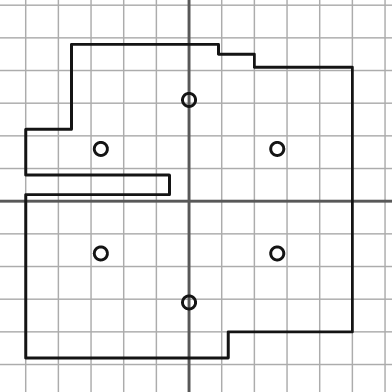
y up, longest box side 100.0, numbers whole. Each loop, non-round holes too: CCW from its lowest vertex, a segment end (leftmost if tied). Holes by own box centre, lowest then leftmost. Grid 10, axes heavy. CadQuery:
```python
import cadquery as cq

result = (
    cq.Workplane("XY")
    .moveTo(-50.0, -48.0)
    .lineTo(12.0, -48.0)
    .lineTo(12.0, -40.0)
    .lineTo(50.0, -40.0)
    .lineTo(50.0, 41.0)
    .lineTo(20.0, 41.0)
    .lineTo(20.0, 45.0)
    .lineTo(9.0, 45.0)
    .lineTo(9.0, 48.0)
    .lineTo(-36.0, 48.0)
    .lineTo(-36.0, 22.0)
    .lineTo(-50.0, 22.0)
    .lineTo(-50.0, 8.0)
    .lineTo(-6.0, 8.0)
    .lineTo(-6.0, 2.0)
    .lineTo(-50.0, 2.0)
    .close()
    .moveTo(0.0, -31.0)
    .circle(2.0)
    .moveTo(-27.0, -16.0)
    .circle(2.0)
    .moveTo(27.0, -16.0)
    .circle(2.0)
    .moveTo(-27.0, 16.0)
    .circle(2.0)
    .moveTo(27.0, 16.0)
    .circle(2.0)
    .moveTo(0.0, 31.0)
    .circle(2.0)
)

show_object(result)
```